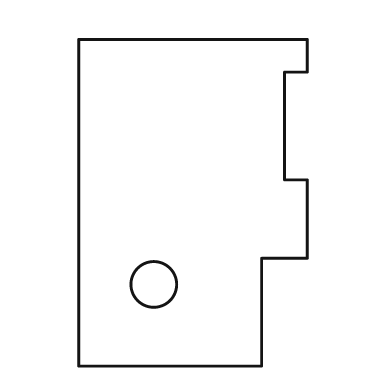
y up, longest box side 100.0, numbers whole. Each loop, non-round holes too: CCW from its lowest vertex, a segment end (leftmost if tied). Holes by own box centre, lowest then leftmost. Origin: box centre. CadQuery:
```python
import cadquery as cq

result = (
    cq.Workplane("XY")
    .moveTo(-35.0, -50.0)
    .lineTo(21.0, -50.0)
    .lineTo(21.0, -17.0)
    .lineTo(35.0, -17.0)
    .lineTo(35.0, 7.0)
    .lineTo(28.0, 7.0)
    .lineTo(28.0, 40.0)
    .lineTo(35.0, 40.0)
    .lineTo(35.0, 50.0)
    .lineTo(-35.0, 50.0)
    .close()
    .moveTo(-12.0, -25.0)
    .circle(7.0)
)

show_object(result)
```